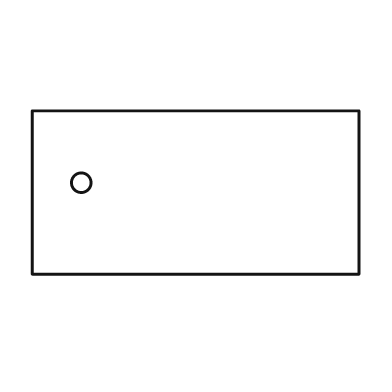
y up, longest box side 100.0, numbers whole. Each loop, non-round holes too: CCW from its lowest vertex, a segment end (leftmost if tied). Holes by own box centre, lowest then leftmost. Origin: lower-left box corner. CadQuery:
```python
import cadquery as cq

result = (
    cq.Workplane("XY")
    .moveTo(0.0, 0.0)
    .lineTo(100.0, 0.0)
    .lineTo(100.0, 50.0)
    .lineTo(0.0, 50.0)
    .close()
    .moveTo(15.0, 28.0)
    .circle(3.0)
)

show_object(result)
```